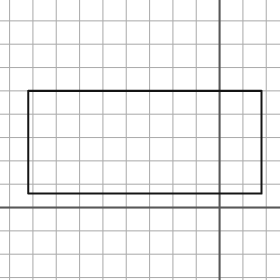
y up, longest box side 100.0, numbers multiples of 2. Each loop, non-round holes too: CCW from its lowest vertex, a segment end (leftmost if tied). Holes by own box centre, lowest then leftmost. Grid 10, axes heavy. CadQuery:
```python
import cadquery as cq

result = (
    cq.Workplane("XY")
    .moveTo(-82.0, 6.0)
    .lineTo(18.0, 6.0)
    .lineTo(18.0, 50.0)
    .lineTo(-82.0, 50.0)
    .close()
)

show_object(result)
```